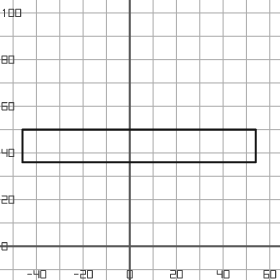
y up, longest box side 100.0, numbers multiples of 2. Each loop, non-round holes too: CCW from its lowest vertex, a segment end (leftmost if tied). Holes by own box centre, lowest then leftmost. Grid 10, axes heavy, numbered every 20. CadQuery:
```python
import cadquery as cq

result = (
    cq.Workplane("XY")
    .moveTo(-46.0, 36.0)
    .lineTo(54.0, 36.0)
    .lineTo(54.0, 50.0)
    .lineTo(-46.0, 50.0)
    .close()
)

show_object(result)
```